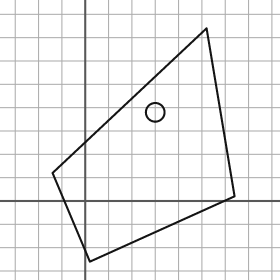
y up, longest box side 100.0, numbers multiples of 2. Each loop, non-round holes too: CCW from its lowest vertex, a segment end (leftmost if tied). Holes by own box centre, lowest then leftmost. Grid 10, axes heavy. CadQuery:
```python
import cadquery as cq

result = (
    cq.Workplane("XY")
    .moveTo(2.0, -26.0)
    .lineTo(64.0, 2.0)
    .lineTo(52.0, 74.0)
    .lineTo(-14.0, 12.0)
    .close()
    .moveTo(30.0, 38.0)
    .circle(4.0)
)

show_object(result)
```